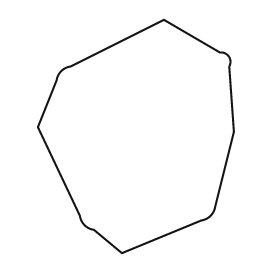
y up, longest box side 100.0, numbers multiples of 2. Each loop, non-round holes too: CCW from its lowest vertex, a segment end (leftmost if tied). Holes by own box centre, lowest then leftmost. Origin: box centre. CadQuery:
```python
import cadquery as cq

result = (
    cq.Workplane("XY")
    .moveTo(-6.0, -50.0)
    .lineTo(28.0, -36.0)
    .threePointArc((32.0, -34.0), (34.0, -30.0))
    .lineTo(42.0, 2.0)
    .lineTo(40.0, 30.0)
    .threePointArc((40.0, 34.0), (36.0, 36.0))
    .lineTo(12.0, 50.0)
    .lineTo(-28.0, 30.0)
    .threePointArc((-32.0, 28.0), (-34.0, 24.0))
    .lineTo(-42.0, 4.0)
    .lineTo(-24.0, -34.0)
    .threePointArc((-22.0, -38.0), (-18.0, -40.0))
    .close()
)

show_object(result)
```